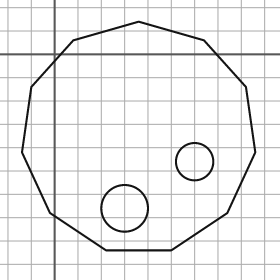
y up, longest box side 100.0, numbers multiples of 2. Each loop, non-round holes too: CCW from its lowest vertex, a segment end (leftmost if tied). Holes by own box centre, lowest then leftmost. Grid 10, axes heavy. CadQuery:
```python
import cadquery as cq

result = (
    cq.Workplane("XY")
    .moveTo(22.0, -84.0)
    .lineTo(50.0, -84.0)
    .lineTo(74.0, -68.0)
    .lineTo(86.0, -42.0)
    .lineTo(82.0, -14.0)
    .lineTo(64.0, 6.0)
    .lineTo(36.0, 14.0)
    .lineTo(8.0, 6.0)
    .lineTo(-10.0, -14.0)
    .lineTo(-14.0, -42.0)
    .lineTo(-2.0, -68.0)
    .close()
    .moveTo(30.0, -66.0)
    .circle(10.0)
    .moveTo(60.0, -46.0)
    .circle(8.0)
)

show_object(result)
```